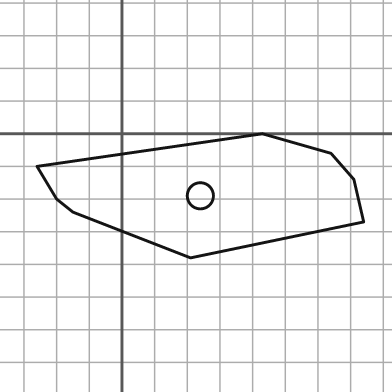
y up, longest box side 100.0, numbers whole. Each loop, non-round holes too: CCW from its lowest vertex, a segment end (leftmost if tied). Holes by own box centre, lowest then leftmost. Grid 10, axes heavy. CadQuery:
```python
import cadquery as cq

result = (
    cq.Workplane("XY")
    .moveTo(21.0, -38.0)
    .lineTo(74.0, -27.0)
    .lineTo(71.0, -14.0)
    .lineTo(64.0, -6.0)
    .lineTo(43.0, 0.0)
    .lineTo(-26.0, -10.0)
    .lineTo(-20.0, -20.0)
    .lineTo(-15.0, -24.0)
    .close()
    .moveTo(24.0, -19.0)
    .circle(4.0)
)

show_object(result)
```